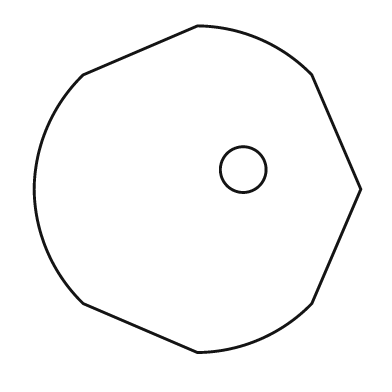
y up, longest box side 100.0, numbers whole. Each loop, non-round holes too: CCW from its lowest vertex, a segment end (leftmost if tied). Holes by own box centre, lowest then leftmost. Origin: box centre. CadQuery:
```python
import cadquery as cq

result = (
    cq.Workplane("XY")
    .moveTo(0.0, -50.0)
    .threePointArc((19.0, -46.0), (35.0, -35.0))
    .lineTo(50.0, 0.0)
    .lineTo(35.0, 35.0)
    .threePointArc((19.0, 46.0), (0.0, 50.0))
    .lineTo(-35.0, 35.0)
    .threePointArc((-46.0, 19.0), (-50.0, 0.0))
    .threePointArc((-46.0, -19.0), (-35.0, -35.0))
    .close()
    .moveTo(14.0, 6.0)
    .circle(7.0)
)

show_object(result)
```